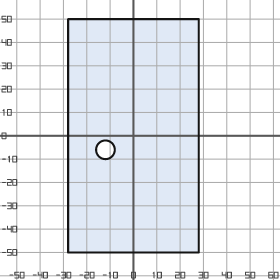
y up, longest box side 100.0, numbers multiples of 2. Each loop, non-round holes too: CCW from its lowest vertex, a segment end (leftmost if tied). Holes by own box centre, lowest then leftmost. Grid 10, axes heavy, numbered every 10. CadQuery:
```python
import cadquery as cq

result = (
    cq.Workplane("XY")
    .moveTo(-28.0, -50.0)
    .lineTo(28.0, -50.0)
    .lineTo(28.0, 50.0)
    .lineTo(-28.0, 50.0)
    .close()
    .moveTo(-12.0, -6.0)
    .circle(4.0)
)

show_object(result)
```